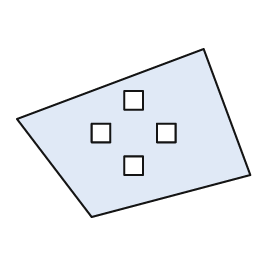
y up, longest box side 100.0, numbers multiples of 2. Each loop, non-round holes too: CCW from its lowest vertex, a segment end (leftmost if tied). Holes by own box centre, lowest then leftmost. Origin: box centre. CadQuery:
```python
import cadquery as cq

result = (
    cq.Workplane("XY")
    .moveTo(-18.0, -36.0)
    .lineTo(50.0, -18.0)
    .lineTo(30.0, 36.0)
    .lineTo(-50.0, 6.0)
    .close()
    .moveTo(-4.0, -18.0)
    .lineTo(4.0, -18.0)
    .lineTo(4.0, -10.0)
    .lineTo(-4.0, -10.0)
    .close()
    .moveTo(-18.0, -4.0)
    .lineTo(-10.0, -4.0)
    .lineTo(-10.0, 4.0)
    .lineTo(-18.0, 4.0)
    .close()
    .moveTo(10.0, -4.0)
    .lineTo(18.0, -4.0)
    .lineTo(18.0, 4.0)
    .lineTo(10.0, 4.0)
    .close()
    .moveTo(-4.0, 10.0)
    .lineTo(4.0, 10.0)
    .lineTo(4.0, 18.0)
    .lineTo(-4.0, 18.0)
    .close()
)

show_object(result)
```